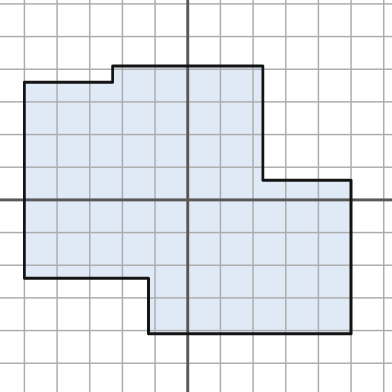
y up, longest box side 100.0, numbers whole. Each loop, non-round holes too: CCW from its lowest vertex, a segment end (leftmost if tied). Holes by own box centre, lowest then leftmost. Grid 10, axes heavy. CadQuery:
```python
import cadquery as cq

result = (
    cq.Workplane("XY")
    .moveTo(-12.0, -41.0)
    .lineTo(50.0, -41.0)
    .lineTo(50.0, 6.0)
    .lineTo(23.0, 6.0)
    .lineTo(23.0, 41.0)
    .lineTo(-23.0, 41.0)
    .lineTo(-23.0, 36.0)
    .lineTo(-50.0, 36.0)
    .lineTo(-50.0, -24.0)
    .lineTo(-12.0, -24.0)
    .close()
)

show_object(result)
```